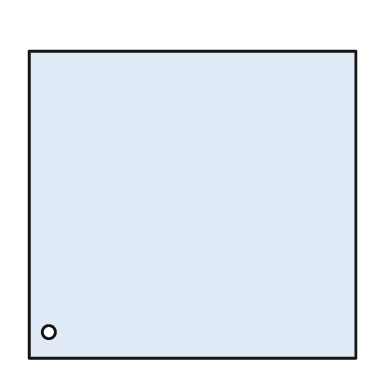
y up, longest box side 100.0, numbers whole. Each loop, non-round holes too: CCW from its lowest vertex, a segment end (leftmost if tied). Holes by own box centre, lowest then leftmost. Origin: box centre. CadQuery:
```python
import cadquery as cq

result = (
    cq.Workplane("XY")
    .moveTo(-50.0, -47.0)
    .lineTo(50.0, -47.0)
    .lineTo(50.0, 47.0)
    .lineTo(-50.0, 47.0)
    .close()
    .moveTo(-44.0, -39.0)
    .circle(2.0)
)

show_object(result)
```